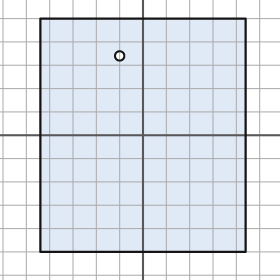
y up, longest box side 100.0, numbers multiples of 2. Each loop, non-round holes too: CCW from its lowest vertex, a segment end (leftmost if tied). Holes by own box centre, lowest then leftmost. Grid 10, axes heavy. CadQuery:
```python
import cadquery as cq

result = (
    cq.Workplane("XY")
    .moveTo(-44.0, -50.0)
    .lineTo(44.0, -50.0)
    .lineTo(44.0, 50.0)
    .lineTo(-44.0, 50.0)
    .close()
    .moveTo(-10.0, 34.0)
    .circle(2.0)
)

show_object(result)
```